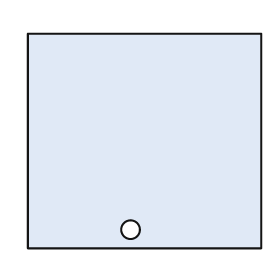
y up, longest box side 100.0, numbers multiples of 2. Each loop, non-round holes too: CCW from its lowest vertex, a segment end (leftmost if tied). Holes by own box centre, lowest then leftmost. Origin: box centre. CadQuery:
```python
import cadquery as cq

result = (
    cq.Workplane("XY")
    .moveTo(-50.0, -46.0)
    .lineTo(50.0, -46.0)
    .lineTo(50.0, 46.0)
    .lineTo(-50.0, 46.0)
    .close()
    .moveTo(-6.0, -38.0)
    .circle(4.0)
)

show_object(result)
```